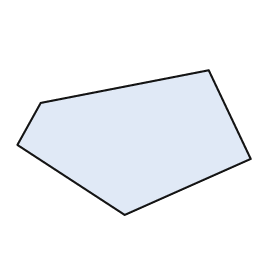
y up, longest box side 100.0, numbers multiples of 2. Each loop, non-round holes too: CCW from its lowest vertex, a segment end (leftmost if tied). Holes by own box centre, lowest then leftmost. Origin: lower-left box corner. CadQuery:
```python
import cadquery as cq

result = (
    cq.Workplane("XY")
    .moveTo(46.0, 0.0)
    .lineTo(100.0, 24.0)
    .lineTo(82.0, 62.0)
    .lineTo(10.0, 48.0)
    .lineTo(0.0, 30.0)
    .close()
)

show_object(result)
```